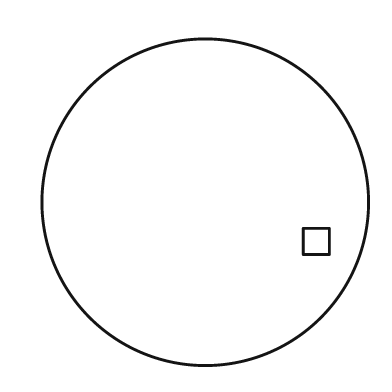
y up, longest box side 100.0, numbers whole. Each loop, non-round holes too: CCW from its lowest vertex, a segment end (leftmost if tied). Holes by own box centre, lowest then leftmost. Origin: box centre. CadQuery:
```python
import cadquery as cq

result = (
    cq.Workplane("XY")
    .moveTo(0.0, 0.0)
    .circle(50.0)
    .moveTo(30.0, -16.0)
    .lineTo(38.0, -16.0)
    .lineTo(38.0, -8.0)
    .lineTo(30.0, -8.0)
    .close()
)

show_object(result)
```